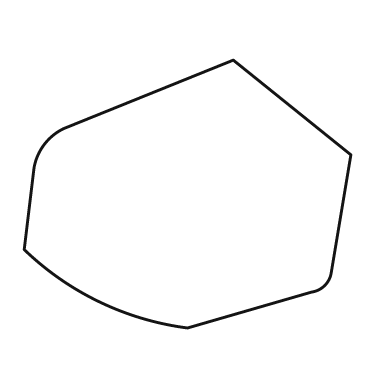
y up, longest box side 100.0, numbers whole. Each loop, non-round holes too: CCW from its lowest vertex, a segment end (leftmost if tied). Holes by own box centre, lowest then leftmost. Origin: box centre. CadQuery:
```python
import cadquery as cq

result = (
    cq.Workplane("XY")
    .moveTo(0.0, -41.0)
    .lineTo(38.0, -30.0)
    .threePointArc((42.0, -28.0), (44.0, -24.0))
    .lineTo(50.0, 12.0)
    .lineTo(14.0, 41.0)
    .lineTo(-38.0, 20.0)
    .threePointArc((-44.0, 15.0), (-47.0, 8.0))
    .lineTo(-50.0, -17.0)
    .threePointArc((-27.0, -33.0), (0.0, -41.0))
    .close()
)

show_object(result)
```